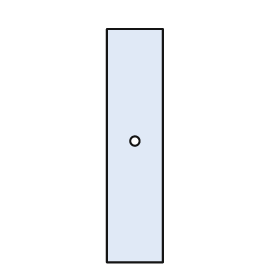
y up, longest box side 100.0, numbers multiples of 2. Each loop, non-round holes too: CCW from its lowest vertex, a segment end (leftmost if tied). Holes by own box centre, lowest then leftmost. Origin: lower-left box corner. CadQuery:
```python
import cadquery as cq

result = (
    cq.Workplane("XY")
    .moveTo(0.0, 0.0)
    .lineTo(24.0, 0.0)
    .lineTo(24.0, 100.0)
    .lineTo(0.0, 100.0)
    .close()
    .moveTo(12.0, 52.0)
    .circle(2.0)
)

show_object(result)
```